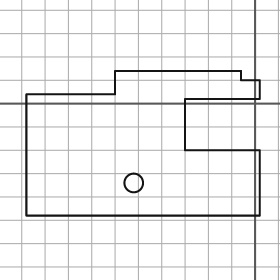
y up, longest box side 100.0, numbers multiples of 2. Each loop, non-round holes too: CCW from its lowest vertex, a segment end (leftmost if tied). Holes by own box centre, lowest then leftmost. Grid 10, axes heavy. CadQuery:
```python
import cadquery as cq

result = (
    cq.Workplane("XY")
    .moveTo(-98.0, -48.0)
    .lineTo(2.0, -48.0)
    .lineTo(2.0, -20.0)
    .lineTo(-30.0, -20.0)
    .lineTo(-30.0, 2.0)
    .lineTo(2.0, 2.0)
    .lineTo(2.0, 10.0)
    .lineTo(-6.0, 10.0)
    .lineTo(-6.0, 14.0)
    .lineTo(-60.0, 14.0)
    .lineTo(-60.0, 4.0)
    .lineTo(-98.0, 4.0)
    .close()
    .moveTo(-52.0, -34.0)
    .circle(4.0)
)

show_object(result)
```